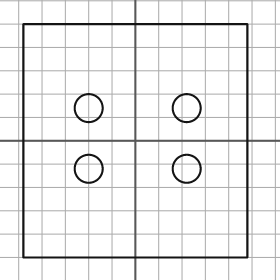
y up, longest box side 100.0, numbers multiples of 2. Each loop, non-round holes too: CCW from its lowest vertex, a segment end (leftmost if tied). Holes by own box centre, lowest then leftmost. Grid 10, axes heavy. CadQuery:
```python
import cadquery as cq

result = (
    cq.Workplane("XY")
    .moveTo(-48.0, -50.0)
    .lineTo(48.0, -50.0)
    .lineTo(48.0, 50.0)
    .lineTo(-48.0, 50.0)
    .close()
    .moveTo(-20.0, -12.0)
    .circle(6.0)
    .moveTo(22.0, -12.0)
    .circle(6.0)
    .moveTo(-20.0, 14.0)
    .circle(6.0)
    .moveTo(22.0, 14.0)
    .circle(6.0)
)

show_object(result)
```